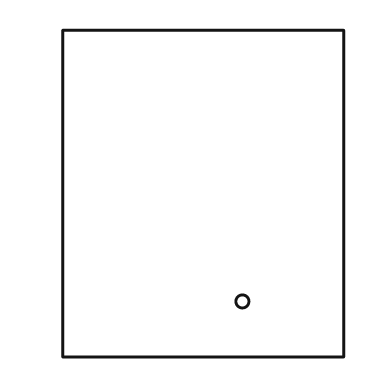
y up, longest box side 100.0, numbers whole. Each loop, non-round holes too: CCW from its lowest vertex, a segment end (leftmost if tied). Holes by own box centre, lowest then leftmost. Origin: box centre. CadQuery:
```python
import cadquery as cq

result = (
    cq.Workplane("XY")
    .moveTo(-43.0, -50.0)
    .lineTo(43.0, -50.0)
    .lineTo(43.0, 50.0)
    .lineTo(-43.0, 50.0)
    .close()
    .moveTo(12.0, -33.0)
    .circle(2.0)
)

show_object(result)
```